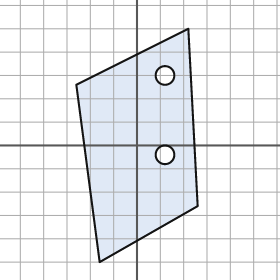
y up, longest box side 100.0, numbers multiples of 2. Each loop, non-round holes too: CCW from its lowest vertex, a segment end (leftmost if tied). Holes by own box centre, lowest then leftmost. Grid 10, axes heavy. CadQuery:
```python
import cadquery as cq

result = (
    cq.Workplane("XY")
    .moveTo(-16.0, -50.0)
    .lineTo(26.0, -26.0)
    .lineTo(22.0, 50.0)
    .lineTo(-26.0, 26.0)
    .close()
    .moveTo(12.0, -4.0)
    .circle(4.0)
    .moveTo(12.0, 30.0)
    .circle(4.0)
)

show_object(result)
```